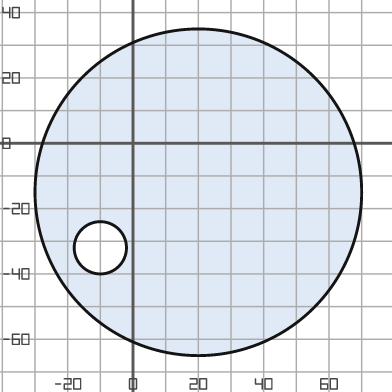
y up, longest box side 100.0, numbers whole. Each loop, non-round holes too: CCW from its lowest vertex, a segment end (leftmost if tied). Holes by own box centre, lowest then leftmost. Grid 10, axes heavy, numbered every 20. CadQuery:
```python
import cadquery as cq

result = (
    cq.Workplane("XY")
    .moveTo(20.0, -15.0)
    .circle(50.0)
    .moveTo(-10.0, -32.0)
    .circle(8.0)
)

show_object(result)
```